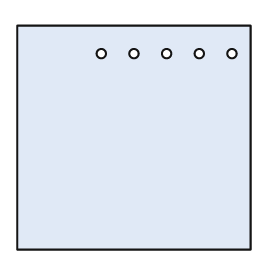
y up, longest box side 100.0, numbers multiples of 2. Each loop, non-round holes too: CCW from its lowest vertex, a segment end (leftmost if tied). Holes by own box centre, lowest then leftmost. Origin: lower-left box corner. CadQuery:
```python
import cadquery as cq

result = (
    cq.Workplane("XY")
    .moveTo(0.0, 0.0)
    .lineTo(100.0, 0.0)
    .lineTo(100.0, 96.0)
    .lineTo(0.0, 96.0)
    .close()
    .moveTo(36.0, 84.0)
    .circle(2.0)
    .moveTo(50.0, 84.0)
    .circle(2.0)
    .moveTo(64.0, 84.0)
    .circle(2.0)
    .moveTo(78.0, 84.0)
    .circle(2.0)
    .moveTo(92.0, 84.0)
    .circle(2.0)
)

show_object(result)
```